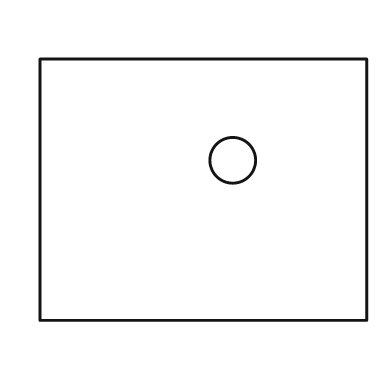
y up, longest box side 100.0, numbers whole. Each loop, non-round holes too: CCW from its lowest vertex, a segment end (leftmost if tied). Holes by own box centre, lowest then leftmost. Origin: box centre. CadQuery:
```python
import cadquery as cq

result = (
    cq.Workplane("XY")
    .moveTo(-50.0, -40.0)
    .lineTo(50.0, -40.0)
    .lineTo(50.0, 40.0)
    .lineTo(-50.0, 40.0)
    .close()
    .moveTo(9.0, 9.0)
    .circle(7.0)
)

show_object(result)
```